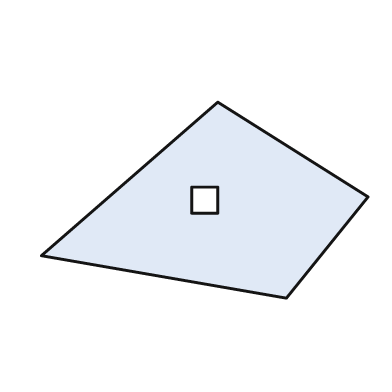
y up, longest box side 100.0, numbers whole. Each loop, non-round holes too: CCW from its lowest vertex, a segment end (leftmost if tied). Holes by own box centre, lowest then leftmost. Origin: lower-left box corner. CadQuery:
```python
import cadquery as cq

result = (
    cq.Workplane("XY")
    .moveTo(75.0, 0.0)
    .lineTo(100.0, 31.0)
    .lineTo(54.0, 60.0)
    .lineTo(0.0, 13.0)
    .close()
    .moveTo(46.0, 26.0)
    .lineTo(54.0, 26.0)
    .lineTo(54.0, 34.0)
    .lineTo(46.0, 34.0)
    .close()
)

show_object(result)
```